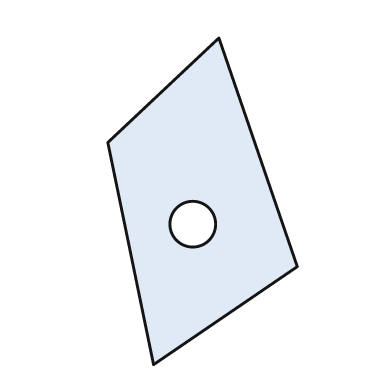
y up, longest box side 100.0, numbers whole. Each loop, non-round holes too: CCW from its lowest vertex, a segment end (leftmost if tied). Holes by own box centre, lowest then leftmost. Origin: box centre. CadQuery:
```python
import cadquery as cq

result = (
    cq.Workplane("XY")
    .moveTo(-15.0, -50.0)
    .lineTo(29.0, -20.0)
    .lineTo(5.0, 50.0)
    .lineTo(-29.0, 18.0)
    .close()
    .moveTo(-3.0, -7.0)
    .circle(7.0)
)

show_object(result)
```